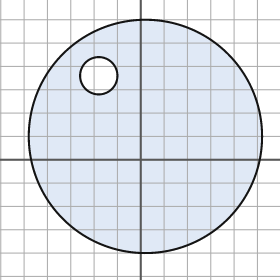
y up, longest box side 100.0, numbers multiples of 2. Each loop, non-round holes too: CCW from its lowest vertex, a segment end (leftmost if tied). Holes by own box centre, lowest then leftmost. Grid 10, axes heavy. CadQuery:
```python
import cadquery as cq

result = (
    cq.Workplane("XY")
    .moveTo(2.0, 10.0)
    .circle(50.0)
    .moveTo(-18.0, 36.0)
    .circle(8.0)
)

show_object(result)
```